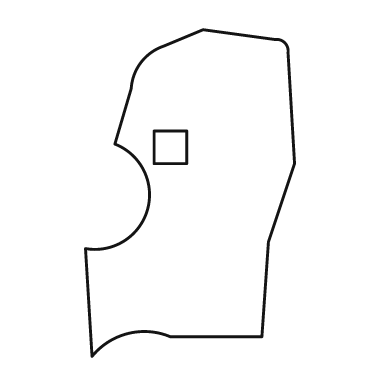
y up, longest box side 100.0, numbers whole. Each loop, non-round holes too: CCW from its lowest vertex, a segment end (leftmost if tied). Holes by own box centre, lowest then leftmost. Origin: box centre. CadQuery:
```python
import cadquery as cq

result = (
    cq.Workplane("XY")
    .moveTo(-30.0, -50.0)
    .threePointArc((-19.0, -43.0), (-6.0, -44.0))
    .lineTo(22.0, -44.0)
    .lineTo(24.0, -15.0)
    .lineTo(32.0, 9.0)
    .lineTo(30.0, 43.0)
    .threePointArc((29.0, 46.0), (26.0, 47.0))
    .lineTo(4.0, 50.0)
    .lineTo(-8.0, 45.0)
    .threePointArc((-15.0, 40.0), (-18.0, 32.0))
    .lineTo(-23.0, 15.0)
    .threePointArc((-13.0, -5.0), (-32.0, -17.0))
    .close()
    .moveTo(-11.0, 9.0)
    .lineTo(-1.0, 9.0)
    .lineTo(-1.0, 19.0)
    .lineTo(-11.0, 19.0)
    .close()
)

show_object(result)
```